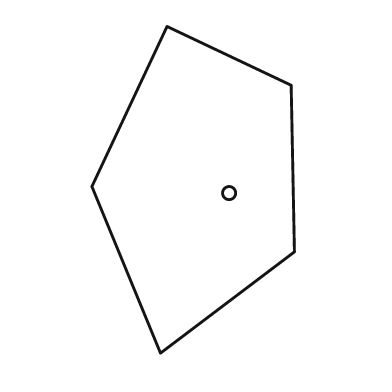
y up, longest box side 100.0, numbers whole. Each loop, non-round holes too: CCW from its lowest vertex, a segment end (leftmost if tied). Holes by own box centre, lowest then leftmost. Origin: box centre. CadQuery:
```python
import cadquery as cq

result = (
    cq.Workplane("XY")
    .moveTo(-10.0, -50.0)
    .lineTo(31.0, -19.0)
    .lineTo(30.0, 32.0)
    .lineTo(-8.0, 50.0)
    .lineTo(-31.0, 1.0)
    .close()
    .moveTo(11.0, -1.0)
    .circle(2.0)
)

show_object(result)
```